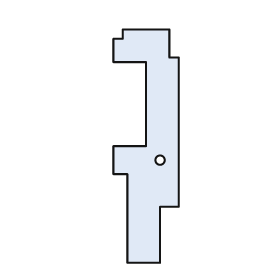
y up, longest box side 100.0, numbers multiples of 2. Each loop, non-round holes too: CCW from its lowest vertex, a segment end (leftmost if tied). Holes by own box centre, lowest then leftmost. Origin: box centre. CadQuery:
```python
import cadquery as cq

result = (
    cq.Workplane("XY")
    .moveTo(-8.0, -50.0)
    .lineTo(6.0, -50.0)
    .lineTo(6.0, -26.0)
    .lineTo(14.0, -26.0)
    .lineTo(14.0, 38.0)
    .lineTo(10.0, 38.0)
    .lineTo(10.0, 50.0)
    .lineTo(-10.0, 50.0)
    .lineTo(-10.0, 46.0)
    .lineTo(-14.0, 46.0)
    .lineTo(-14.0, 36.0)
    .lineTo(0.0, 36.0)
    .lineTo(0.0, 0.0)
    .lineTo(-14.0, 0.0)
    .lineTo(-14.0, -12.0)
    .lineTo(-8.0, -12.0)
    .close()
    .moveTo(6.0, -6.0)
    .circle(2.0)
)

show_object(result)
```